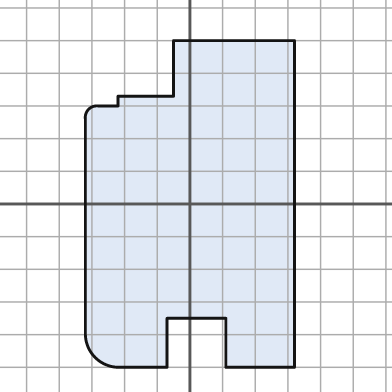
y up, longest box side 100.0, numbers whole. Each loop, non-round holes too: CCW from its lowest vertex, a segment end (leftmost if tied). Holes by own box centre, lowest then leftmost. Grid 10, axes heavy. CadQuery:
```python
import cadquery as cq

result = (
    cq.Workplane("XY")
    .moveTo(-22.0, -50.0)
    .lineTo(-7.0, -50.0)
    .lineTo(-7.0, -35.0)
    .lineTo(11.0, -35.0)
    .lineTo(11.0, -50.0)
    .lineTo(32.0, -50.0)
    .lineTo(32.0, 50.0)
    .lineTo(-5.0, 50.0)
    .lineTo(-5.0, 33.0)
    .lineTo(-22.0, 33.0)
    .lineTo(-22.0, 30.0)
    .lineTo(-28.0, 30.0)
    .threePointArc((-31.0, 29.0), (-32.0, 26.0))
    .lineTo(-32.0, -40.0)
    .threePointArc((-29.0, -47.0), (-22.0, -50.0))
    .close()
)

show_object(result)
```